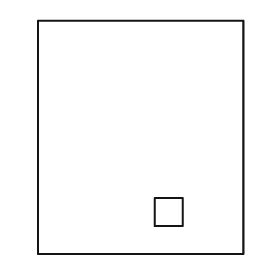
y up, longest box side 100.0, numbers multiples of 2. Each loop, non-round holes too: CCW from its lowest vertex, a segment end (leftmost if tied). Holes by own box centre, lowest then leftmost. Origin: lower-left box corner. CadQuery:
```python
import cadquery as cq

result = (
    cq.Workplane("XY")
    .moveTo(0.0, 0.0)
    .lineTo(88.0, 0.0)
    .lineTo(88.0, 100.0)
    .lineTo(0.0, 100.0)
    .close()
    .moveTo(50.0, 12.0)
    .lineTo(62.0, 12.0)
    .lineTo(62.0, 24.0)
    .lineTo(50.0, 24.0)
    .close()
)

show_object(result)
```